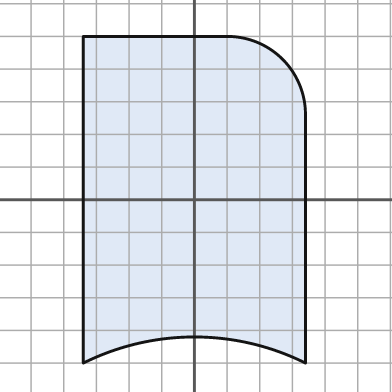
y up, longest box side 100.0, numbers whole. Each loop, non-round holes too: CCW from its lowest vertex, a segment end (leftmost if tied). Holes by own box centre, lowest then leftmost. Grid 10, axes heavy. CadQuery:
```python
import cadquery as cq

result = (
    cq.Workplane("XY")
    .moveTo(-34.0, -50.0)
    .threePointArc((0.0, -42.0), (34.0, -50.0))
    .lineTo(34.0, 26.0)
    .threePointArc((27.0, 43.0), (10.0, 50.0))
    .lineTo(-34.0, 50.0)
    .close()
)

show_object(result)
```